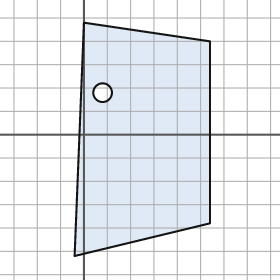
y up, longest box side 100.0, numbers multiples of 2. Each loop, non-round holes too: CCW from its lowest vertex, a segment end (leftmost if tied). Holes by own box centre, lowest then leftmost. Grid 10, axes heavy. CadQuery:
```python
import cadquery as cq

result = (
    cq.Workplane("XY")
    .moveTo(-4.0, -52.0)
    .lineTo(54.0, -38.0)
    .lineTo(54.0, 40.0)
    .lineTo(0.0, 48.0)
    .close()
    .moveTo(8.0, 18.0)
    .circle(4.0)
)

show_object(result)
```